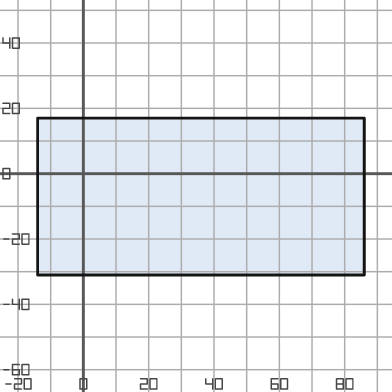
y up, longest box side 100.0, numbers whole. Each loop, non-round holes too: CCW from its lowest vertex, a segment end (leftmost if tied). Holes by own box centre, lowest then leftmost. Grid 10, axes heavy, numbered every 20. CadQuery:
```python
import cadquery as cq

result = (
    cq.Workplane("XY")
    .moveTo(-14.0, -31.0)
    .lineTo(86.0, -31.0)
    .lineTo(86.0, 17.0)
    .lineTo(-14.0, 17.0)
    .close()
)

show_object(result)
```